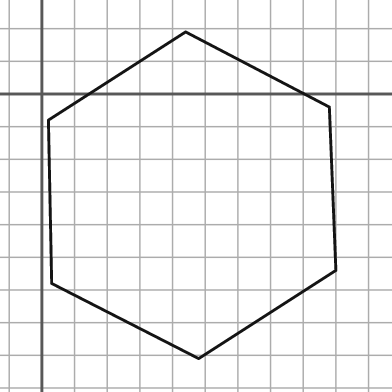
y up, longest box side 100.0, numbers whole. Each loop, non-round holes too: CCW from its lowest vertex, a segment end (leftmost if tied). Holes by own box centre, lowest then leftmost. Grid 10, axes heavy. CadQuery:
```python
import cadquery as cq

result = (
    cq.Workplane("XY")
    .moveTo(48.0, -81.0)
    .lineTo(90.0, -54.0)
    .lineTo(88.0, -4.0)
    .lineTo(44.0, 19.0)
    .lineTo(2.0, -8.0)
    .lineTo(3.0, -58.0)
    .close()
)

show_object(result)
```